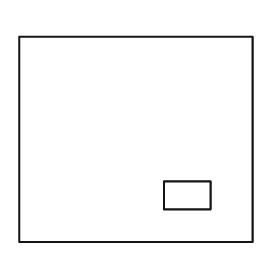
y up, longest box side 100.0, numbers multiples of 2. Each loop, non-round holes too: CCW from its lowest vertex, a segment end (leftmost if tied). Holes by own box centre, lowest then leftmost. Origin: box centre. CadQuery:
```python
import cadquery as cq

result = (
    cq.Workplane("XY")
    .moveTo(-50.0, -44.0)
    .lineTo(50.0, -44.0)
    .lineTo(50.0, 44.0)
    .lineTo(-50.0, 44.0)
    .close()
    .moveTo(12.0, -30.0)
    .lineTo(32.0, -30.0)
    .lineTo(32.0, -18.0)
    .lineTo(12.0, -18.0)
    .close()
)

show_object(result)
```